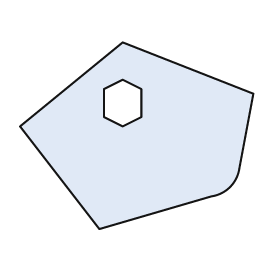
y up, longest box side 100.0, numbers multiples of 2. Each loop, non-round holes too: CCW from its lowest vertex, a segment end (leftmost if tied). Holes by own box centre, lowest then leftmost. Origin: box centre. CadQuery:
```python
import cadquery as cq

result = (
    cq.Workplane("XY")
    .moveTo(-16.0, -40.0)
    .lineTo(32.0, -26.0)
    .threePointArc((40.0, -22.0), (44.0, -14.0))
    .lineTo(50.0, 18.0)
    .lineTo(-6.0, 40.0)
    .lineTo(-50.0, 4.0)
    .close()
    .moveTo(-6.0, 4.0)
    .lineTo(2.0, 8.0)
    .lineTo(2.0, 20.0)
    .lineTo(-6.0, 24.0)
    .lineTo(-14.0, 20.0)
    .lineTo(-14.0, 8.0)
    .close()
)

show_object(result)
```